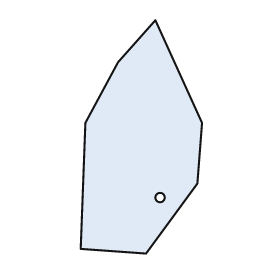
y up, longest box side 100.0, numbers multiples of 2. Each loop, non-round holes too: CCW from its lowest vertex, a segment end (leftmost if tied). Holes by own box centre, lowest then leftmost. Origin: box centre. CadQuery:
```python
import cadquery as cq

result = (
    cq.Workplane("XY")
    .moveTo(2.0, -50.0)
    .lineTo(24.0, -20.0)
    .lineTo(26.0, 6.0)
    .lineTo(6.0, 50.0)
    .lineTo(-10.0, 32.0)
    .lineTo(-24.0, 6.0)
    .lineTo(-26.0, -48.0)
    .close()
    .moveTo(8.0, -26.0)
    .circle(2.0)
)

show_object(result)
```